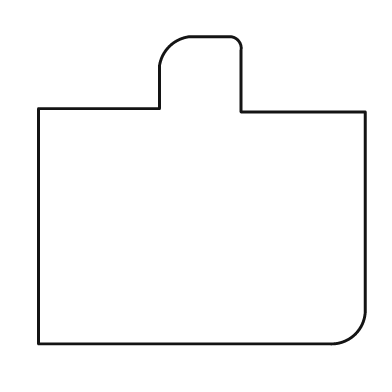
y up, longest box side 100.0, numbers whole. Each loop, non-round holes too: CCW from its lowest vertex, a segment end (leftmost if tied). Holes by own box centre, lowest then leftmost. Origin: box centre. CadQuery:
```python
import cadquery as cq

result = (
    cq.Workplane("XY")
    .moveTo(-50.0, -47.0)
    .lineTo(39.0, -47.0)
    .threePointArc((47.0, -44.0), (50.0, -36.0))
    .lineTo(50.0, 24.0)
    .lineTo(12.0, 24.0)
    .lineTo(12.0, 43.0)
    .threePointArc((11.0, 46.0), (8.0, 47.0))
    .lineTo(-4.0, 47.0)
    .threePointArc((-10.0, 44.0), (-13.0, 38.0))
    .lineTo(-13.0, 25.0)
    .lineTo(-50.0, 25.0)
    .close()
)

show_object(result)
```